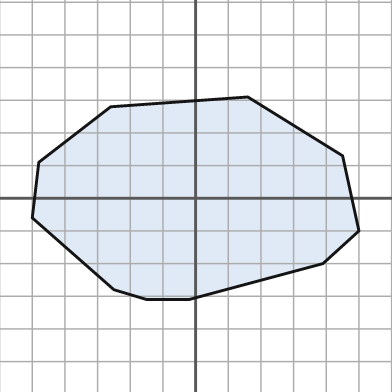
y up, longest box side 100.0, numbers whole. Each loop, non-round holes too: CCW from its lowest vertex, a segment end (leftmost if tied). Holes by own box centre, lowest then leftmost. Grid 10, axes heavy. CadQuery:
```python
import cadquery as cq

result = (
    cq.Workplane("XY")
    .moveTo(-15.0, -31.0)
    .lineTo(-2.0, -31.0)
    .lineTo(39.0, -20.0)
    .lineTo(50.0, -10.0)
    .lineTo(45.0, 13.0)
    .lineTo(16.0, 31.0)
    .lineTo(-26.0, 28.0)
    .lineTo(-48.0, 11.0)
    .lineTo(-50.0, -6.0)
    .lineTo(-25.0, -28.0)
    .close()
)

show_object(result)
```